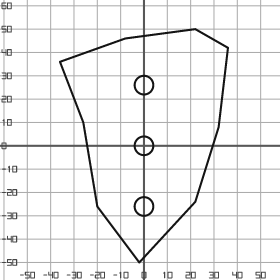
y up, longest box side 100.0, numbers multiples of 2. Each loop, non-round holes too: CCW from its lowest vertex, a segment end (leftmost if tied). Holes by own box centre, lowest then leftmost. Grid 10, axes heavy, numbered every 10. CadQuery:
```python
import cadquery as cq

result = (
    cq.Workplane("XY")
    .moveTo(-2.0, -50.0)
    .lineTo(22.0, -24.0)
    .lineTo(32.0, 8.0)
    .lineTo(36.0, 42.0)
    .lineTo(22.0, 50.0)
    .lineTo(-8.0, 46.0)
    .lineTo(-36.0, 36.0)
    .lineTo(-26.0, 10.0)
    .lineTo(-20.0, -26.0)
    .close()
    .moveTo(0.0, -26.0)
    .circle(4.0)
    .moveTo(0.0, 0.0)
    .circle(4.0)
    .moveTo(0.0, 26.0)
    .circle(4.0)
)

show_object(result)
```